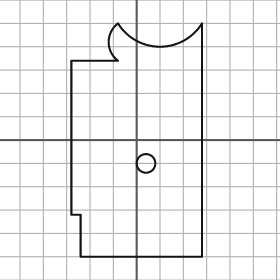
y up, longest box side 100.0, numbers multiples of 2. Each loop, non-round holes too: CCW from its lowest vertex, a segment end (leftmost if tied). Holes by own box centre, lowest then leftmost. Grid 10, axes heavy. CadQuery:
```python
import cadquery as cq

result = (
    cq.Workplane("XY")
    .moveTo(-24.0, -50.0)
    .lineTo(28.0, -50.0)
    .lineTo(28.0, 50.0)
    .threePointArc((10.0, 40.0), (-8.0, 50.0))
    .threePointArc((-12.0, 42.0), (-8.0, 34.0))
    .lineTo(-28.0, 34.0)
    .lineTo(-28.0, -32.0)
    .lineTo(-24.0, -32.0)
    .close()
    .moveTo(4.0, -10.0)
    .circle(4.0)
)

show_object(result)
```